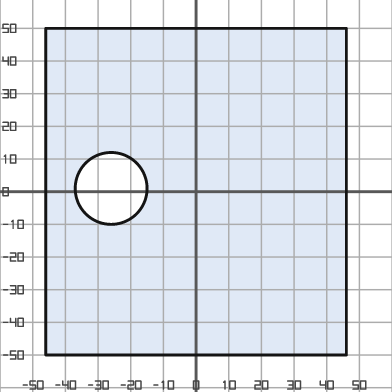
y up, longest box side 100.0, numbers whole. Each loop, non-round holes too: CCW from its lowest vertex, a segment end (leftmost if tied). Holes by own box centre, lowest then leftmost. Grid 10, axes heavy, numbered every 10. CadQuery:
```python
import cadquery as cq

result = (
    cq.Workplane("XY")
    .moveTo(-46.0, -50.0)
    .lineTo(46.0, -50.0)
    .lineTo(46.0, 50.0)
    .lineTo(-46.0, 50.0)
    .close()
    .moveTo(-26.0, 1.0)
    .circle(11.0)
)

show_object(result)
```